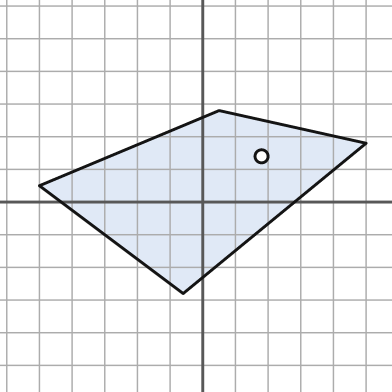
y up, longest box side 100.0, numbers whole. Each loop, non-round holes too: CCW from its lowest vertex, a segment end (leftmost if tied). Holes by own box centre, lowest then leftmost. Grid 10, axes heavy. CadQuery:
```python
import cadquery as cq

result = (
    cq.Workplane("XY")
    .moveTo(-6.0, -28.0)
    .lineTo(50.0, 18.0)
    .lineTo(5.0, 28.0)
    .lineTo(-50.0, 5.0)
    .close()
    .moveTo(18.0, 14.0)
    .circle(2.0)
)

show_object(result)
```